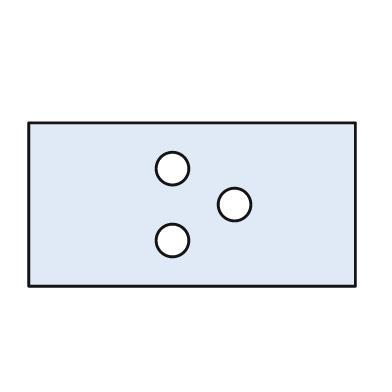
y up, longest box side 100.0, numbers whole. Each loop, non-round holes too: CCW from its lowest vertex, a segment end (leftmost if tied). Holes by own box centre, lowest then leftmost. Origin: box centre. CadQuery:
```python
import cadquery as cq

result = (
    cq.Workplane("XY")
    .moveTo(-50.0, -25.0)
    .lineTo(50.0, -25.0)
    .lineTo(50.0, 25.0)
    .lineTo(-50.0, 25.0)
    .close()
    .moveTo(-6.0, -11.0)
    .circle(5.0)
    .moveTo(13.0, 0.0)
    .circle(5.0)
    .moveTo(-6.0, 11.0)
    .circle(5.0)
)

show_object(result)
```